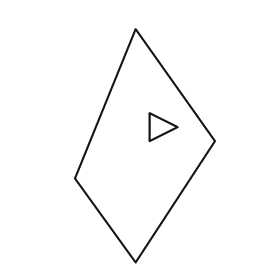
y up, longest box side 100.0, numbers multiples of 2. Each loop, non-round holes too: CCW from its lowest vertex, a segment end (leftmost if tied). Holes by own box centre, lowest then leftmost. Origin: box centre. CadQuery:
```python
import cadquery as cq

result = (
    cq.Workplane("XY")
    .moveTo(-4.0, -50.0)
    .lineTo(30.0, 2.0)
    .lineTo(-4.0, 50.0)
    .lineTo(-30.0, -14.0)
    .close()
    .moveTo(2.0, 2.0)
    .lineTo(14.0, 8.0)
    .lineTo(2.0, 14.0)
    .close()
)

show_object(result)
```